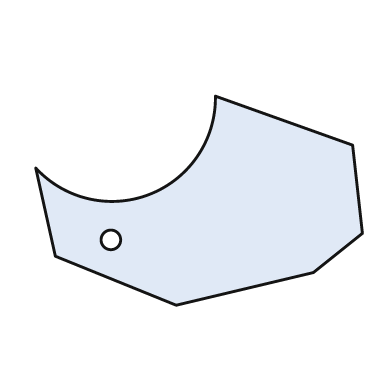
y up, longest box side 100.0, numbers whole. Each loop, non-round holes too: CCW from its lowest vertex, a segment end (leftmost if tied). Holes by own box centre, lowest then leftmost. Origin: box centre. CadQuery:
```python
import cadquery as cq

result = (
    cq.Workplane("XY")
    .moveTo(-7.0, -32.0)
    .lineTo(35.0, -22.0)
    .lineTo(50.0, -10.0)
    .lineTo(47.0, 17.0)
    .lineTo(5.0, 32.0)
    .threePointArc((-15.0, 2.0), (-50.0, 10.0))
    .lineTo(-44.0, -17.0)
    .close()
    .moveTo(-27.0, -12.0)
    .circle(3.0)
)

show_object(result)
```